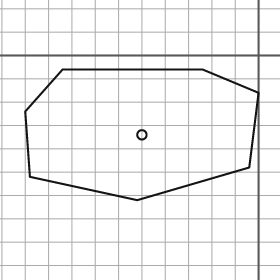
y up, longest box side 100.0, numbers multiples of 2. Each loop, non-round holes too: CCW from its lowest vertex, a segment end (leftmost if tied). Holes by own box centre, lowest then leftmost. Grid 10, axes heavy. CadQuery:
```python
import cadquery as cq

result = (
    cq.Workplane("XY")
    .moveTo(-52.0, -62.0)
    .lineTo(-4.0, -48.0)
    .lineTo(0.0, -16.0)
    .lineTo(-24.0, -6.0)
    .lineTo(-84.0, -6.0)
    .lineTo(-100.0, -24.0)
    .lineTo(-98.0, -52.0)
    .close()
    .moveTo(-50.0, -34.0)
    .circle(2.0)
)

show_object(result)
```